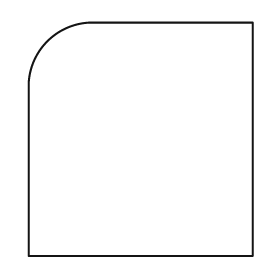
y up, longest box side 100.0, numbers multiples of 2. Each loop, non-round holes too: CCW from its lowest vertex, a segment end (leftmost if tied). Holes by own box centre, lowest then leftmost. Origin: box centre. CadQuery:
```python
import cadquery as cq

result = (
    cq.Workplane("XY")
    .moveTo(-48.0, -50.0)
    .lineTo(48.0, -50.0)
    .lineTo(48.0, 50.0)
    .lineTo(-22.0, 50.0)
    .threePointArc((-40.0, 42.0), (-48.0, 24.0))
    .close()
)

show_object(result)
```